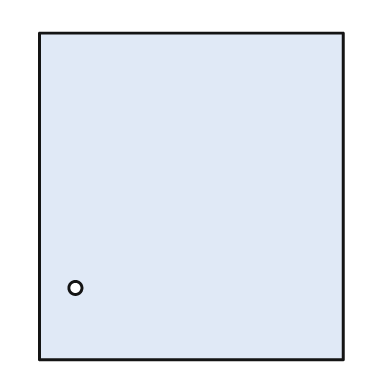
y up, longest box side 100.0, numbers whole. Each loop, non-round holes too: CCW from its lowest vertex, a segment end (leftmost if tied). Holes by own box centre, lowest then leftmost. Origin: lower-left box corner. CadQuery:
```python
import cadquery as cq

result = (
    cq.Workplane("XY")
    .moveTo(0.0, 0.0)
    .lineTo(93.0, 0.0)
    .lineTo(93.0, 100.0)
    .lineTo(0.0, 100.0)
    .close()
    .moveTo(11.0, 22.0)
    .circle(2.0)
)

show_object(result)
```